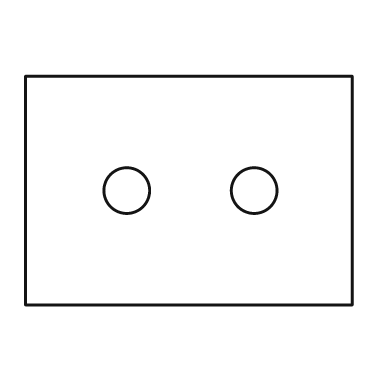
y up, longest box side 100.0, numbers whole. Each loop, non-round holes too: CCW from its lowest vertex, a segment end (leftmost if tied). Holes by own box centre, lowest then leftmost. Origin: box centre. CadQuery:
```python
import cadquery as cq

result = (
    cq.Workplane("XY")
    .moveTo(-50.0, -35.0)
    .lineTo(50.0, -35.0)
    .lineTo(50.0, 35.0)
    .lineTo(-50.0, 35.0)
    .close()
    .moveTo(-19.0, 0.0)
    .circle(7.0)
    .moveTo(20.0, 0.0)
    .circle(7.0)
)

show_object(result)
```